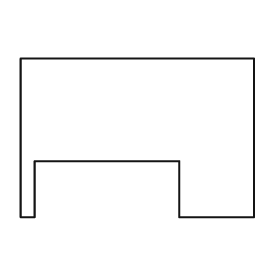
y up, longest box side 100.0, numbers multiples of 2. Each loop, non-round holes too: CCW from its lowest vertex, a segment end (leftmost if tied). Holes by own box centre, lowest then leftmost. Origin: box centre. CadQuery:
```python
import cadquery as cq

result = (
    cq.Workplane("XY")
    .moveTo(-50.0, -34.0)
    .lineTo(-44.0, -34.0)
    .lineTo(-44.0, -10.0)
    .lineTo(18.0, -10.0)
    .lineTo(18.0, -34.0)
    .lineTo(50.0, -34.0)
    .lineTo(50.0, 34.0)
    .lineTo(-50.0, 34.0)
    .close()
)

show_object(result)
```